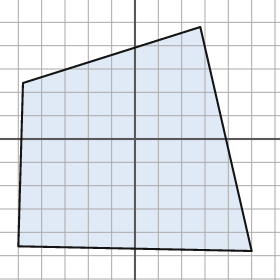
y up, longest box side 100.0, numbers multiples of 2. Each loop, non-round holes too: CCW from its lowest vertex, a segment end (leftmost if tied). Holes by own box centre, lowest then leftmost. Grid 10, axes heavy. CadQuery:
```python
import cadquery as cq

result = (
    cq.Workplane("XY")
    .moveTo(50.0, -48.0)
    .lineTo(28.0, 48.0)
    .lineTo(-48.0, 24.0)
    .lineTo(-50.0, -46.0)
    .close()
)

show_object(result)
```